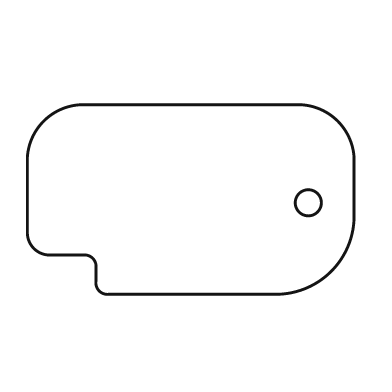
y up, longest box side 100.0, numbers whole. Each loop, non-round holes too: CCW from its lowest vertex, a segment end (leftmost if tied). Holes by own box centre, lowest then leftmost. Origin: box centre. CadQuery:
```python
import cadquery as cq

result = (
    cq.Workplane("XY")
    .moveTo(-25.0, -29.0)
    .lineTo(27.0, -29.0)
    .threePointArc((43.0, -22.0), (50.0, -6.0))
    .lineTo(50.0, 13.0)
    .threePointArc((45.0, 24.0), (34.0, 29.0))
    .lineTo(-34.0, 29.0)
    .threePointArc((-45.0, 24.0), (-50.0, 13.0))
    .lineTo(-50.0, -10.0)
    .threePointArc((-48.0, -15.0), (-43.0, -17.0))
    .lineTo(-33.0, -17.0)
    .threePointArc((-30.0, -18.0), (-29.0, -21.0))
    .lineTo(-29.0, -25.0)
    .threePointArc((-28.0, -28.0), (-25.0, -29.0))
    .close()
    .moveTo(36.0, -1.0)
    .circle(4.0)
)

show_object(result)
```